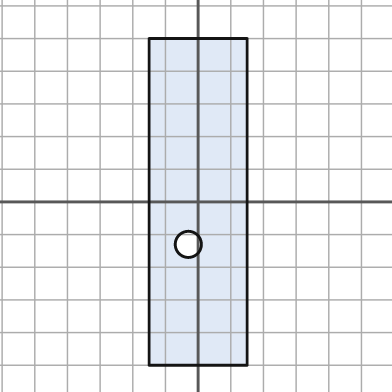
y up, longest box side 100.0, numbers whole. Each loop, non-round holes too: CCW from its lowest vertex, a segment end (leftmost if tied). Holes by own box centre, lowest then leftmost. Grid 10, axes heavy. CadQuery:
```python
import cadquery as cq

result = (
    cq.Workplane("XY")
    .moveTo(-15.0, -50.0)
    .lineTo(15.0, -50.0)
    .lineTo(15.0, 50.0)
    .lineTo(-15.0, 50.0)
    .close()
    .moveTo(-3.0, -13.0)
    .circle(4.0)
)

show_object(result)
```